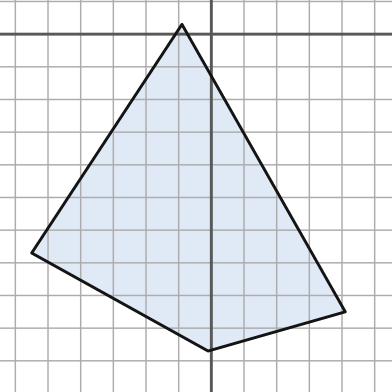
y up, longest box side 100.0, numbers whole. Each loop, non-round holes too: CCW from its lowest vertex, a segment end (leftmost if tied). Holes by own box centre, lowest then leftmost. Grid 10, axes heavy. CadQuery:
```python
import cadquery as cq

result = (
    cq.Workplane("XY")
    .moveTo(-1.0, -97.0)
    .lineTo(41.0, -85.0)
    .lineTo(-9.0, 3.0)
    .lineTo(-55.0, -67.0)
    .close()
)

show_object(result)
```